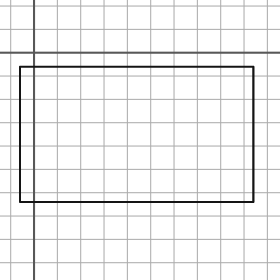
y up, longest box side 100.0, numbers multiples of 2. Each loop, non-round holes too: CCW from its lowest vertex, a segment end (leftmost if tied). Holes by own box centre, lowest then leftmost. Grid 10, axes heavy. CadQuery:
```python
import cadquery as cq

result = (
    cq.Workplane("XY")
    .moveTo(-6.0, -64.0)
    .lineTo(94.0, -64.0)
    .lineTo(94.0, -6.0)
    .lineTo(-6.0, -6.0)
    .close()
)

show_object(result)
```